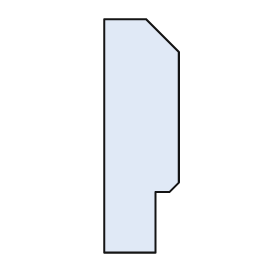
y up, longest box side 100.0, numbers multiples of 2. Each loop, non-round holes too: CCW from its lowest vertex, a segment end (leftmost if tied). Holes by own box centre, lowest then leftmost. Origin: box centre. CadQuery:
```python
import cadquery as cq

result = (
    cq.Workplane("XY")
    .moveTo(-16.0, -50.0)
    .lineTo(6.0, -50.0)
    .lineTo(6.0, -24.0)
    .lineTo(12.0, -24.0)
    .lineTo(16.0, -20.0)
    .lineTo(16.0, 36.0)
    .lineTo(2.0, 50.0)
    .lineTo(-16.0, 50.0)
    .close()
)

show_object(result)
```